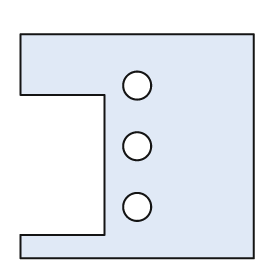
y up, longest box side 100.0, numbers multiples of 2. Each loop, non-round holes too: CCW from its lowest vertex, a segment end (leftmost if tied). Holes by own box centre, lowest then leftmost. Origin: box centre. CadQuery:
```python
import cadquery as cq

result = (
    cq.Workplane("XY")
    .moveTo(-50.0, -48.0)
    .lineTo(50.0, -48.0)
    .lineTo(50.0, 48.0)
    .lineTo(-50.0, 48.0)
    .lineTo(-50.0, 22.0)
    .lineTo(-14.0, 22.0)
    .lineTo(-14.0, -38.0)
    .lineTo(-50.0, -38.0)
    .close()
    .moveTo(0.0, -26.0)
    .circle(6.0)
    .moveTo(0.0, 0.0)
    .circle(6.0)
    .moveTo(0.0, 26.0)
    .circle(6.0)
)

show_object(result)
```